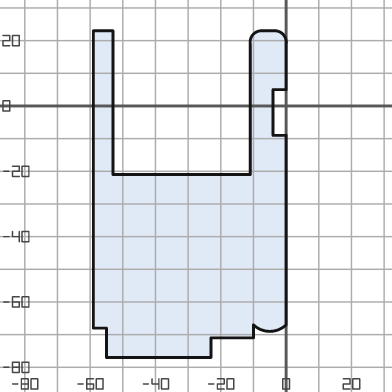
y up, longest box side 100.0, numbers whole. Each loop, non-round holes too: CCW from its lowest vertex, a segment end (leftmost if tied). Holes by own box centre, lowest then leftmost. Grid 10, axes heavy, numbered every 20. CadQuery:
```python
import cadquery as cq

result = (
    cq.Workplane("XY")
    .moveTo(-55.0, -77.0)
    .lineTo(-23.0, -77.0)
    .lineTo(-23.0, -71.0)
    .lineTo(-10.0, -71.0)
    .lineTo(-10.0, -67.0)
    .threePointArc((-5.0, -69.0), (0.0, -67.0))
    .lineTo(0.0, -9.0)
    .lineTo(-4.0, -9.0)
    .lineTo(-4.0, 5.0)
    .lineTo(0.0, 5.0)
    .lineTo(0.0, 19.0)
    .threePointArc((-1.0, 22.0), (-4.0, 23.0))
    .lineTo(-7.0, 23.0)
    .threePointArc((-10.0, 22.0), (-11.0, 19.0))
    .lineTo(-11.0, -21.0)
    .lineTo(-53.0, -21.0)
    .lineTo(-53.0, 23.0)
    .lineTo(-59.0, 23.0)
    .lineTo(-59.0, -68.0)
    .lineTo(-55.0, -68.0)
    .close()
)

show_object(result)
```